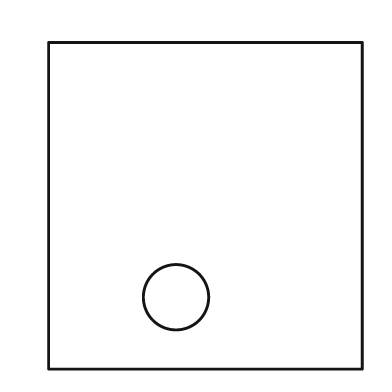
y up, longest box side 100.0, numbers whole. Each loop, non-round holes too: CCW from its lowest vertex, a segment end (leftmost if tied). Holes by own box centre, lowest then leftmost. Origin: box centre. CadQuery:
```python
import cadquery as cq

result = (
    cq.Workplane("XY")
    .moveTo(-48.0, -50.0)
    .lineTo(48.0, -50.0)
    .lineTo(48.0, 50.0)
    .lineTo(-48.0, 50.0)
    .close()
    .moveTo(-9.0, -28.0)
    .circle(10.0)
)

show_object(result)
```